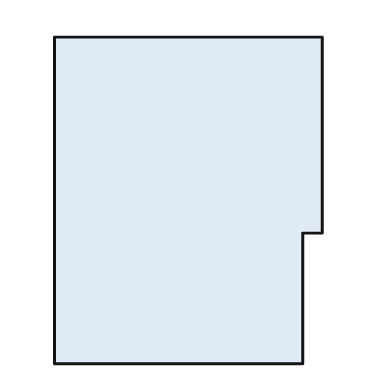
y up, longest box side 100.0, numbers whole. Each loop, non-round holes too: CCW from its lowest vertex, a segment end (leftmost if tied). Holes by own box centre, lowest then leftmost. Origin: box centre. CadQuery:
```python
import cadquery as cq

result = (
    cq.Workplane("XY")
    .moveTo(-41.0, -50.0)
    .lineTo(35.0, -50.0)
    .lineTo(35.0, -10.0)
    .lineTo(41.0, -10.0)
    .lineTo(41.0, 50.0)
    .lineTo(-41.0, 50.0)
    .close()
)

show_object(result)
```